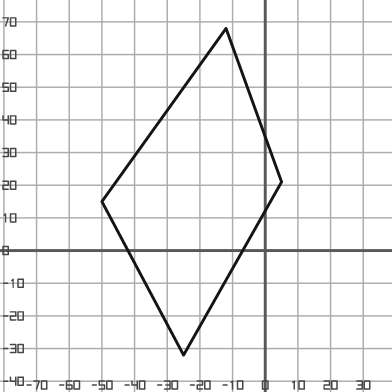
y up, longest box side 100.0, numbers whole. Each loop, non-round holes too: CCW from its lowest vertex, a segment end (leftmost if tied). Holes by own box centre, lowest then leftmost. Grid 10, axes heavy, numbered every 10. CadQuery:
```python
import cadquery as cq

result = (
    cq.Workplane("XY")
    .moveTo(-25.0, -32.0)
    .lineTo(5.0, 21.0)
    .lineTo(-12.0, 68.0)
    .lineTo(-50.0, 15.0)
    .close()
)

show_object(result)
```